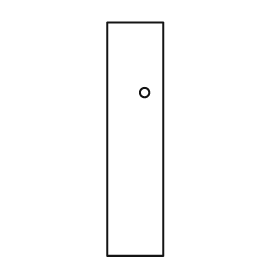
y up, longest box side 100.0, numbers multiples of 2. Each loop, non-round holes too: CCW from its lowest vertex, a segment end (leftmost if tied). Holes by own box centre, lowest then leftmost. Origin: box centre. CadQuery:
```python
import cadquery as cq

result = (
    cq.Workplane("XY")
    .moveTo(-12.0, -50.0)
    .lineTo(12.0, -50.0)
    .lineTo(12.0, 50.0)
    .lineTo(-12.0, 50.0)
    .close()
    .moveTo(4.0, 20.0)
    .circle(2.0)
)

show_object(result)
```